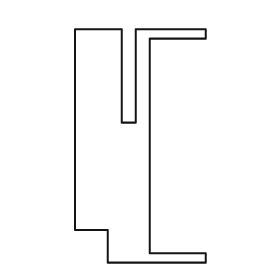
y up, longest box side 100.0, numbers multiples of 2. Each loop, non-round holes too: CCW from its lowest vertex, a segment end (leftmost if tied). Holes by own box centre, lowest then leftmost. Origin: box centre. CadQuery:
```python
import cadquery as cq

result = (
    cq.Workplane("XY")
    .moveTo(-14.0, -50.0)
    .lineTo(28.0, -50.0)
    .lineTo(28.0, -46.0)
    .lineTo(4.0, -46.0)
    .lineTo(4.0, 46.0)
    .lineTo(28.0, 46.0)
    .lineTo(28.0, 50.0)
    .lineTo(-2.0, 50.0)
    .lineTo(-2.0, 10.0)
    .lineTo(-8.0, 10.0)
    .lineTo(-8.0, 50.0)
    .lineTo(-28.0, 50.0)
    .lineTo(-28.0, -36.0)
    .lineTo(-14.0, -36.0)
    .close()
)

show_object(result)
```